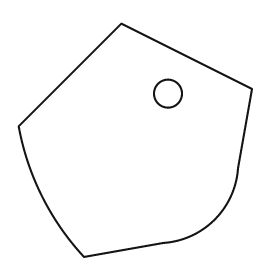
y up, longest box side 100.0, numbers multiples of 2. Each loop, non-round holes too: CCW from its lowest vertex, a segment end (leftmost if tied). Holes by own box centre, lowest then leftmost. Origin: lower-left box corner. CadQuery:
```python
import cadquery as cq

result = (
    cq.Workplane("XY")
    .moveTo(28.0, 0.0)
    .lineTo(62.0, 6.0)
    .threePointArc((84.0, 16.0), (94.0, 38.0))
    .lineTo(100.0, 72.0)
    .lineTo(44.0, 100.0)
    .lineTo(0.0, 56.0)
    .threePointArc((10.0, 26.0), (28.0, 0.0))
    .close()
    .moveTo(64.0, 70.0)
    .circle(6.0)
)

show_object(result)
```